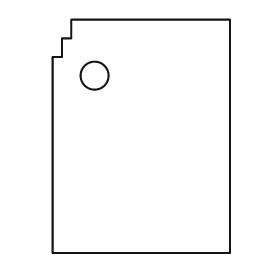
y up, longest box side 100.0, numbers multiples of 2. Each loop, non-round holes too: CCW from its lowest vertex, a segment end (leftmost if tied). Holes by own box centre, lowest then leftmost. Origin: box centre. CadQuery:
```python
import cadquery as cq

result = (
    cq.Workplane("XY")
    .moveTo(-38.0, -50.0)
    .lineTo(38.0, -50.0)
    .lineTo(38.0, 50.0)
    .lineTo(-30.0, 50.0)
    .lineTo(-30.0, 42.0)
    .lineTo(-34.0, 42.0)
    .lineTo(-34.0, 34.0)
    .lineTo(-38.0, 34.0)
    .close()
    .moveTo(-20.0, 26.0)
    .circle(6.0)
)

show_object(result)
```